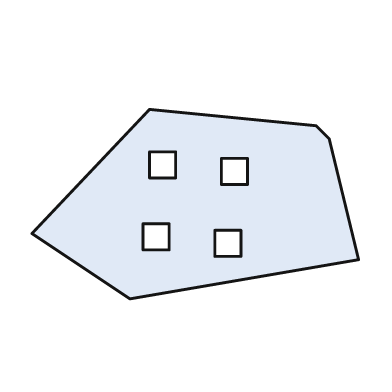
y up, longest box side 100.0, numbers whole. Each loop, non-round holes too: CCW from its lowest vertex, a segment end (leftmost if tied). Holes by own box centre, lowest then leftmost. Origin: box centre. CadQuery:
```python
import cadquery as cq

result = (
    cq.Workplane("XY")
    .moveTo(-20.0, -29.0)
    .lineTo(50.0, -17.0)
    .lineTo(41.0, 20.0)
    .lineTo(37.0, 24.0)
    .lineTo(-14.0, 29.0)
    .lineTo(-50.0, -9.0)
    .close()
    .moveTo(6.0, -16.0)
    .lineTo(14.0, -16.0)
    .lineTo(14.0, -8.0)
    .lineTo(6.0, -8.0)
    .close()
    .moveTo(-16.0, -14.0)
    .lineTo(-8.0, -14.0)
    .lineTo(-8.0, -6.0)
    .lineTo(-16.0, -6.0)
    .close()
    .moveTo(8.0, 6.0)
    .lineTo(16.0, 6.0)
    .lineTo(16.0, 14.0)
    .lineTo(8.0, 14.0)
    .close()
    .moveTo(-14.0, 8.0)
    .lineTo(-6.0, 8.0)
    .lineTo(-6.0, 16.0)
    .lineTo(-14.0, 16.0)
    .close()
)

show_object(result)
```